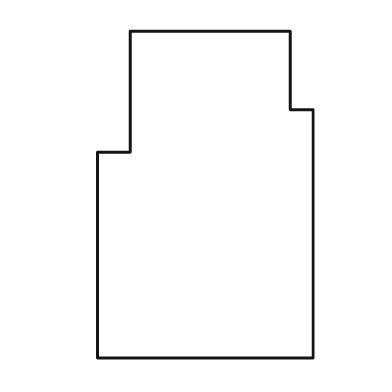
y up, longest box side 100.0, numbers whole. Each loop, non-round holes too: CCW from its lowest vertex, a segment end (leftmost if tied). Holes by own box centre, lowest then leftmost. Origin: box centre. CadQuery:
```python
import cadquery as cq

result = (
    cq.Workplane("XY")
    .moveTo(-33.0, -50.0)
    .lineTo(33.0, -50.0)
    .lineTo(33.0, 26.0)
    .lineTo(26.0, 26.0)
    .lineTo(26.0, 50.0)
    .lineTo(-23.0, 50.0)
    .lineTo(-23.0, 13.0)
    .lineTo(-33.0, 13.0)
    .close()
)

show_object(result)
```